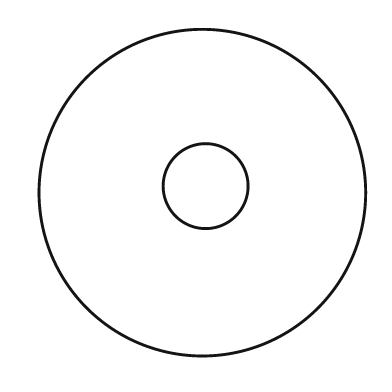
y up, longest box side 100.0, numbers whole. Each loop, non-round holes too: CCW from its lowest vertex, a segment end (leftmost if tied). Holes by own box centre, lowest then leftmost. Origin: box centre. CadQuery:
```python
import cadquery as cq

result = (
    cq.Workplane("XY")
    .moveTo(0.0, 0.0)
    .circle(50.0)
    .moveTo(1.0, 2.0)
    .circle(13.0)
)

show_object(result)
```